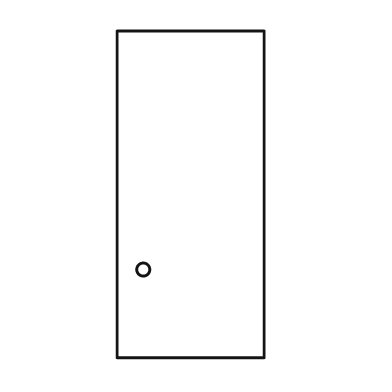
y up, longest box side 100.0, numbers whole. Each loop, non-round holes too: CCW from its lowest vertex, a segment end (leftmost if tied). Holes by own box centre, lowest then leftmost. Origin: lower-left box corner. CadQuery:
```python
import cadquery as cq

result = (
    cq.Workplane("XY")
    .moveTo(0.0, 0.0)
    .lineTo(45.0, 0.0)
    .lineTo(45.0, 100.0)
    .lineTo(0.0, 100.0)
    .close()
    .moveTo(8.0, 27.0)
    .circle(2.0)
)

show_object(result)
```